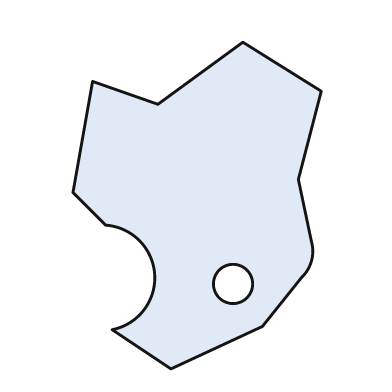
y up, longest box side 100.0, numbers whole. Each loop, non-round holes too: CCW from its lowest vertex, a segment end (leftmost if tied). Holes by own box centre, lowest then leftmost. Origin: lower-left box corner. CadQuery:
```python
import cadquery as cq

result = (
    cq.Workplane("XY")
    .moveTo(30.0, 0.0)
    .lineTo(58.0, 13.0)
    .lineTo(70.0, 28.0)
    .threePointArc((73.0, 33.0), (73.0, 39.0))
    .lineTo(69.0, 58.0)
    .lineTo(76.0, 85.0)
    .lineTo(52.0, 100.0)
    .lineTo(26.0, 81.0)
    .lineTo(6.0, 88.0)
    .lineTo(0.0, 54.0)
    .lineTo(10.0, 44.0)
    .threePointArc((25.0, 29.0), (12.0, 12.0))
    .close()
    .moveTo(49.0, 26.0)
    .circle(6.0)
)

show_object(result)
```